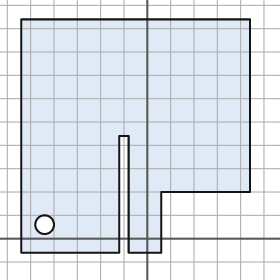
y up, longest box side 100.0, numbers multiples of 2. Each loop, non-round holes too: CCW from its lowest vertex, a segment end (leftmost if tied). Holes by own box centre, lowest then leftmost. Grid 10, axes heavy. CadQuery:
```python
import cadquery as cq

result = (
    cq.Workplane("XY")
    .moveTo(-54.0, -6.0)
    .lineTo(-12.0, -6.0)
    .lineTo(-12.0, 44.0)
    .lineTo(-8.0, 44.0)
    .lineTo(-8.0, -6.0)
    .lineTo(6.0, -6.0)
    .lineTo(6.0, 20.0)
    .lineTo(44.0, 20.0)
    .lineTo(44.0, 94.0)
    .lineTo(-54.0, 94.0)
    .close()
    .moveTo(-44.0, 6.0)
    .circle(4.0)
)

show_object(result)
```